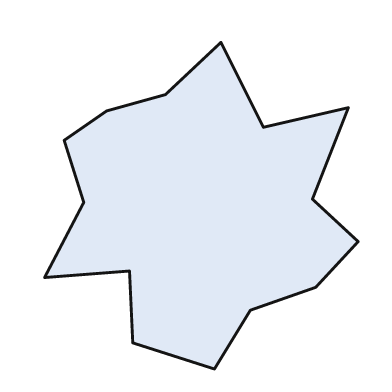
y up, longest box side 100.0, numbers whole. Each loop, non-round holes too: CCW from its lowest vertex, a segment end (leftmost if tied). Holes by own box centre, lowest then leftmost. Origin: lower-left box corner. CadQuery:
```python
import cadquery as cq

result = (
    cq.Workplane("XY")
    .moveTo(52.0, 0.0)
    .lineTo(63.0, 18.0)
    .lineTo(83.0, 25.0)
    .lineTo(96.0, 39.0)
    .lineTo(82.0, 52.0)
    .lineTo(93.0, 80.0)
    .lineTo(67.0, 74.0)
    .lineTo(54.0, 100.0)
    .lineTo(37.0, 84.0)
    .lineTo(19.0, 79.0)
    .lineTo(6.0, 70.0)
    .lineTo(12.0, 51.0)
    .lineTo(0.0, 28.0)
    .lineTo(26.0, 30.0)
    .lineTo(27.0, 8.0)
    .close()
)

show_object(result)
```